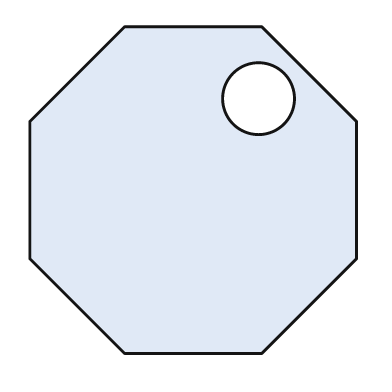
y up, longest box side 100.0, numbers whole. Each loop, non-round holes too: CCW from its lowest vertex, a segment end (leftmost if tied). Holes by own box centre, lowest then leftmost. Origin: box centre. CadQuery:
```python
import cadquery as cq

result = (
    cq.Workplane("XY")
    .moveTo(-21.0, -50.0)
    .lineTo(21.0, -50.0)
    .lineTo(50.0, -21.0)
    .lineTo(50.0, 21.0)
    .lineTo(21.0, 50.0)
    .lineTo(-21.0, 50.0)
    .lineTo(-50.0, 21.0)
    .lineTo(-50.0, -21.0)
    .close()
    .moveTo(20.0, 28.0)
    .circle(11.0)
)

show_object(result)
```